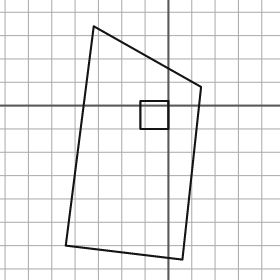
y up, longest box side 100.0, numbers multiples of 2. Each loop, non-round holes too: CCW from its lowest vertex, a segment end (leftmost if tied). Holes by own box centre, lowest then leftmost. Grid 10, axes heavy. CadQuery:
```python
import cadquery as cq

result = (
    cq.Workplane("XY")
    .moveTo(6.0, -66.0)
    .lineTo(14.0, 8.0)
    .lineTo(-32.0, 34.0)
    .lineTo(-44.0, -60.0)
    .close()
    .moveTo(-12.0, -10.0)
    .lineTo(0.0, -10.0)
    .lineTo(0.0, 2.0)
    .lineTo(-12.0, 2.0)
    .close()
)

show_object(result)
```